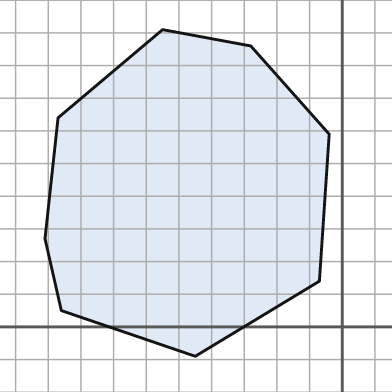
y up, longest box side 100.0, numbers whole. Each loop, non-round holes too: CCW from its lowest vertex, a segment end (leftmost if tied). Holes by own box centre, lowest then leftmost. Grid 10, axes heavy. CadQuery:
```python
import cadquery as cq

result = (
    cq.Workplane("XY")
    .moveTo(-45.0, -9.0)
    .lineTo(-7.0, 14.0)
    .lineTo(-4.0, 59.0)
    .lineTo(-28.0, 86.0)
    .lineTo(-55.0, 91.0)
    .lineTo(-87.0, 64.0)
    .lineTo(-91.0, 27.0)
    .lineTo(-86.0, 5.0)
    .close()
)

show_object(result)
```